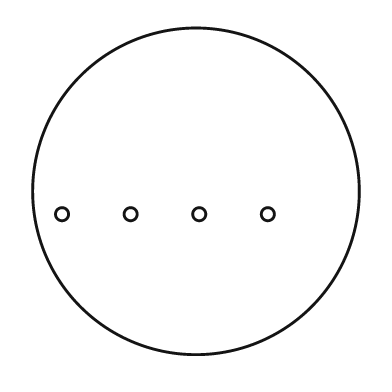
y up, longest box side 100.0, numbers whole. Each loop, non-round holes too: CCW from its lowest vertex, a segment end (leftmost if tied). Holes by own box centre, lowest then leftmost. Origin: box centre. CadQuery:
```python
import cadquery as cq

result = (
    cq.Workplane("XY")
    .moveTo(0.0, 0.0)
    .circle(50.0)
    .moveTo(-41.0, -7.0)
    .circle(2.0)
    .moveTo(-20.0, -7.0)
    .circle(2.0)
    .moveTo(1.0, -7.0)
    .circle(2.0)
    .moveTo(22.0, -7.0)
    .circle(2.0)
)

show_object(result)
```